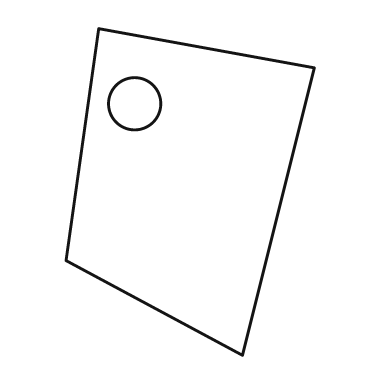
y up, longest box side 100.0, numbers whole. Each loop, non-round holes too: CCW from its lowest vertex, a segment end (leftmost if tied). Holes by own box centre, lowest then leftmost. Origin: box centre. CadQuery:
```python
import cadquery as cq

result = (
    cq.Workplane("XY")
    .moveTo(16.0, -50.0)
    .lineTo(38.0, 38.0)
    .lineTo(-28.0, 50.0)
    .lineTo(-38.0, -21.0)
    .close()
    .moveTo(-17.0, 27.0)
    .circle(8.0)
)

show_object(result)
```